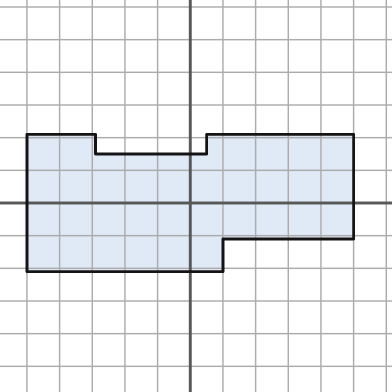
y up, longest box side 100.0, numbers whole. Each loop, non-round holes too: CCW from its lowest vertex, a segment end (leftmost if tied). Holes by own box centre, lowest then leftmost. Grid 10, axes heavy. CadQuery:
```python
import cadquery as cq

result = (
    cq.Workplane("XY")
    .moveTo(-50.0, -21.0)
    .lineTo(10.0, -21.0)
    .lineTo(10.0, -11.0)
    .lineTo(50.0, -11.0)
    .lineTo(50.0, 21.0)
    .lineTo(5.0, 21.0)
    .lineTo(5.0, 15.0)
    .lineTo(-29.0, 15.0)
    .lineTo(-29.0, 21.0)
    .lineTo(-50.0, 21.0)
    .close()
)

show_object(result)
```